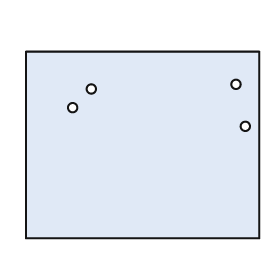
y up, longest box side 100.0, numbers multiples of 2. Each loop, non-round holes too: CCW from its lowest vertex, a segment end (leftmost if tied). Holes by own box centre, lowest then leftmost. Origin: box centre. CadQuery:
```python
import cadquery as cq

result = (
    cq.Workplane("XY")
    .moveTo(-50.0, -40.0)
    .lineTo(50.0, -40.0)
    .lineTo(50.0, 40.0)
    .lineTo(-50.0, 40.0)
    .close()
    .moveTo(44.0, 8.0)
    .circle(2.0)
    .moveTo(-30.0, 16.0)
    .circle(2.0)
    .moveTo(-22.0, 24.0)
    .circle(2.0)
    .moveTo(40.0, 26.0)
    .circle(2.0)
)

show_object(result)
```